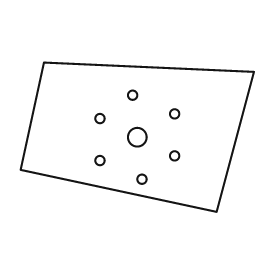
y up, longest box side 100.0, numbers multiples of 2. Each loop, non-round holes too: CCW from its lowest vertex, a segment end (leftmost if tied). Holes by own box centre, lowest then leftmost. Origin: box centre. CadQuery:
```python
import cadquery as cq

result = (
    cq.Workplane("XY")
    .moveTo(34.0, -32.0)
    .lineTo(50.0, 28.0)
    .lineTo(-40.0, 32.0)
    .lineTo(-50.0, -14.0)
    .close()
    .moveTo(2.0, -18.0)
    .circle(2.0)
    .moveTo(-16.0, -10.0)
    .circle(2.0)
    .moveTo(16.0, -8.0)
    .circle(2.0)
    .moveTo(0.0, 0.0)
    .circle(4.0)
    .moveTo(-16.0, 8.0)
    .circle(2.0)
    .moveTo(16.0, 10.0)
    .circle(2.0)
    .moveTo(-2.0, 18.0)
    .circle(2.0)
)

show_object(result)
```